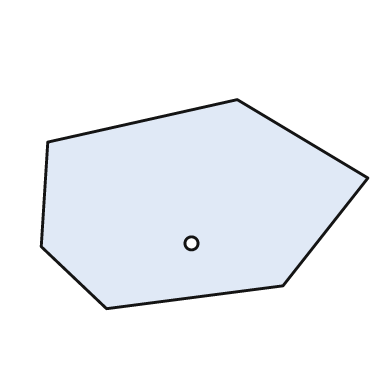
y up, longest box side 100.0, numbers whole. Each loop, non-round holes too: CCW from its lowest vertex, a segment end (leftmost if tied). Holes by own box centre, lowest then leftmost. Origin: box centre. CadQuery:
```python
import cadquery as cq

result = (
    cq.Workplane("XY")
    .moveTo(-30.0, -32.0)
    .lineTo(24.0, -25.0)
    .lineTo(50.0, 8.0)
    .lineTo(10.0, 32.0)
    .lineTo(-48.0, 19.0)
    .lineTo(-50.0, -13.0)
    .close()
    .moveTo(-4.0, -12.0)
    .circle(2.0)
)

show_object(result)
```